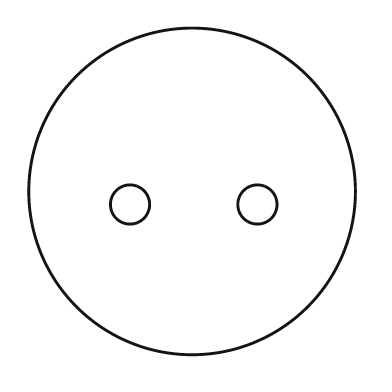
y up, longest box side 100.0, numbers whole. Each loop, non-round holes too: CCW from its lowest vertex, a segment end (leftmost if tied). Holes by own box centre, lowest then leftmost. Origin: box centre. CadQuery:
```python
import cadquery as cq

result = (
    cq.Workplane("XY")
    .moveTo(0.0, 0.0)
    .circle(50.0)
    .moveTo(-19.0, -4.0)
    .circle(6.0)
    .moveTo(20.0, -4.0)
    .circle(6.0)
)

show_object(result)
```